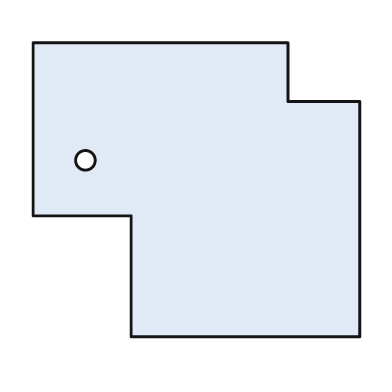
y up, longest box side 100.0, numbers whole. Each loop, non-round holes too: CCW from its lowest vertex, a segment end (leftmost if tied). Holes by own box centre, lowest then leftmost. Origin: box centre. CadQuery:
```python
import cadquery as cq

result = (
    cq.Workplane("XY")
    .moveTo(-20.0, -45.0)
    .lineTo(50.0, -45.0)
    .lineTo(50.0, 27.0)
    .lineTo(28.0, 27.0)
    .lineTo(28.0, 45.0)
    .lineTo(-50.0, 45.0)
    .lineTo(-50.0, -8.0)
    .lineTo(-20.0, -8.0)
    .close()
    .moveTo(-34.0, 9.0)
    .circle(3.0)
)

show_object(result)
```